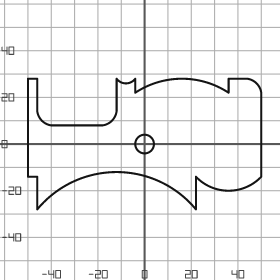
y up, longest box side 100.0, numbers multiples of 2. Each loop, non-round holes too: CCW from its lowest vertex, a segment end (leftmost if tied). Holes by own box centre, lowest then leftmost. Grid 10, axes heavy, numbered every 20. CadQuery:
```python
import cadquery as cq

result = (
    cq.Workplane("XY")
    .moveTo(-46.0, -28.0)
    .threePointArc((-12.0, -12.0), (22.0, -28.0))
    .lineTo(22.0, -14.0)
    .threePointArc((36.0, -20.0), (50.0, -14.0))
    .lineTo(50.0, 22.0)
    .threePointArc((48.0, 26.0), (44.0, 28.0))
    .lineTo(36.0, 28.0)
    .lineTo(36.0, 22.0)
    .threePointArc((16.0, 28.0), (-4.0, 22.0))
    .lineTo(-4.0, 28.0)
    .threePointArc((-8.0, 26.0), (-12.0, 28.0))
    .lineTo(-12.0, 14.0)
    .threePointArc((-14.0, 10.0), (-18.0, 8.0))
    .lineTo(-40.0, 8.0)
    .threePointArc((-44.0, 10.0), (-46.0, 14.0))
    .lineTo(-46.0, 28.0)
    .lineTo(-50.0, 28.0)
    .lineTo(-50.0, -14.0)
    .lineTo(-46.0, -14.0)
    .close()
    .moveTo(0.0, 0.0)
    .circle(4.0)
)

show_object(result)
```